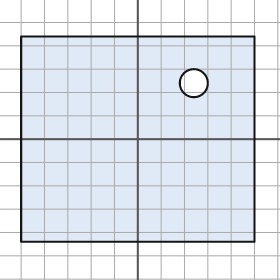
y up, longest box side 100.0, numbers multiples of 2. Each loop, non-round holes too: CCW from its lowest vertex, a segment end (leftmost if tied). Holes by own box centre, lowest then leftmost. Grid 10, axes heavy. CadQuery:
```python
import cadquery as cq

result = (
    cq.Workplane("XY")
    .moveTo(-50.0, -44.0)
    .lineTo(50.0, -44.0)
    .lineTo(50.0, 44.0)
    .lineTo(-50.0, 44.0)
    .close()
    .moveTo(24.0, 24.0)
    .circle(6.0)
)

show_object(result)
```